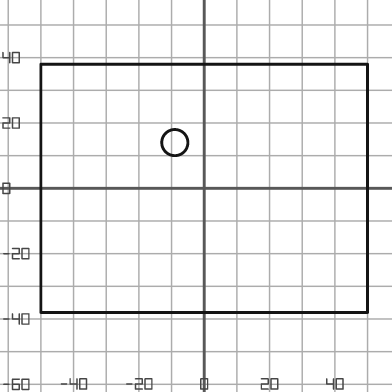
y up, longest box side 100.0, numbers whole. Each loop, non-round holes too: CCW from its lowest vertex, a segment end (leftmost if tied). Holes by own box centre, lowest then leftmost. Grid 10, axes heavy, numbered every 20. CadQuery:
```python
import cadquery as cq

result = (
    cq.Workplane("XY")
    .moveTo(-50.0, -38.0)
    .lineTo(50.0, -38.0)
    .lineTo(50.0, 38.0)
    .lineTo(-50.0, 38.0)
    .close()
    .moveTo(-9.0, 14.0)
    .circle(4.0)
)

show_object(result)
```